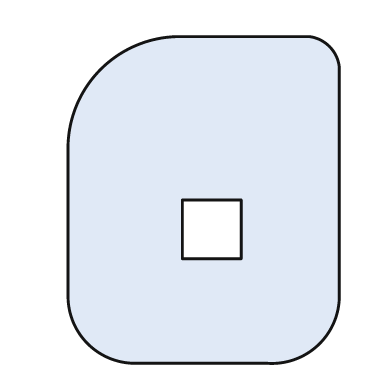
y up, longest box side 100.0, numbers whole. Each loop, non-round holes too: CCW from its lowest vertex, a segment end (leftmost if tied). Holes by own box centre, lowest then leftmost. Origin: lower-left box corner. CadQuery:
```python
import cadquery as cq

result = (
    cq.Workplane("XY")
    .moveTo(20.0, 0.0)
    .lineTo(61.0, 0.0)
    .threePointArc((77.0, 6.0), (83.0, 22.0))
    .lineTo(83.0, 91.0)
    .threePointArc((80.0, 97.0), (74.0, 100.0))
    .lineTo(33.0, 100.0)
    .threePointArc((10.0, 90.0), (0.0, 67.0))
    .lineTo(0.0, 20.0)
    .threePointArc((6.0, 6.0), (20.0, 0.0))
    .close()
    .moveTo(35.0, 32.0)
    .lineTo(53.0, 32.0)
    .lineTo(53.0, 50.0)
    .lineTo(35.0, 50.0)
    .close()
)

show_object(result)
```